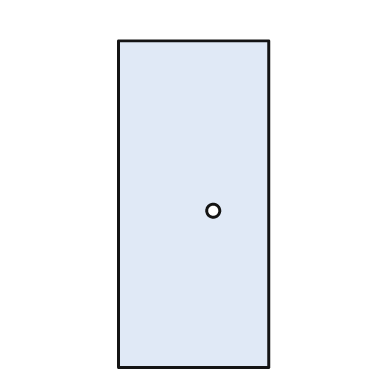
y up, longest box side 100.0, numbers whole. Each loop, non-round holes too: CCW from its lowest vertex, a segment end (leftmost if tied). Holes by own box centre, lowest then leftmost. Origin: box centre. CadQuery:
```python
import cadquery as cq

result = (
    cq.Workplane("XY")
    .moveTo(-23.0, -50.0)
    .lineTo(23.0, -50.0)
    .lineTo(23.0, 50.0)
    .lineTo(-23.0, 50.0)
    .close()
    .moveTo(6.0, -2.0)
    .circle(2.0)
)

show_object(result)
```